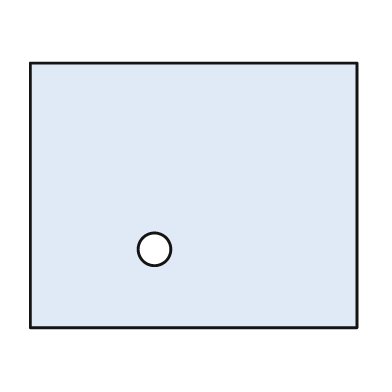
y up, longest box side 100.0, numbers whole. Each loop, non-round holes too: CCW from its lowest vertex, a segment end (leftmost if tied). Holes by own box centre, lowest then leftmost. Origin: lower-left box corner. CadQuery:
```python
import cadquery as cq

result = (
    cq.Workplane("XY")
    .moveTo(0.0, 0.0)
    .lineTo(100.0, 0.0)
    .lineTo(100.0, 81.0)
    .lineTo(0.0, 81.0)
    .close()
    .moveTo(38.0, 24.0)
    .circle(5.0)
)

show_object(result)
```